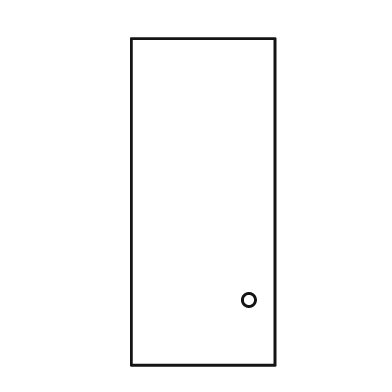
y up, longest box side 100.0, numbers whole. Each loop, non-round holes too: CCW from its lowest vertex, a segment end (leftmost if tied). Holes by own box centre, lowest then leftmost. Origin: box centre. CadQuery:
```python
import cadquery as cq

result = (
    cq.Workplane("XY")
    .moveTo(-22.0, -50.0)
    .lineTo(22.0, -50.0)
    .lineTo(22.0, 50.0)
    .lineTo(-22.0, 50.0)
    .close()
    .moveTo(14.0, -30.0)
    .circle(2.0)
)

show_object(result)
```